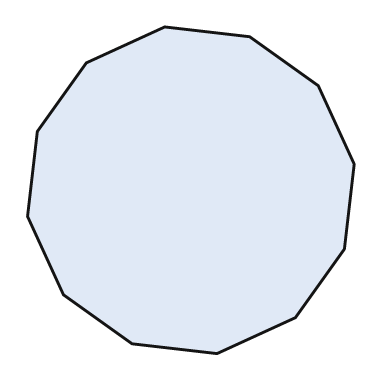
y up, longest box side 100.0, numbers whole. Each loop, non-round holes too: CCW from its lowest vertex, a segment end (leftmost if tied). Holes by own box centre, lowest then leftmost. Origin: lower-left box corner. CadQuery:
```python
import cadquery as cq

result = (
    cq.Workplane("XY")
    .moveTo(58.0, 0.0)
    .lineTo(82.0, 11.0)
    .lineTo(97.0, 32.0)
    .lineTo(100.0, 58.0)
    .lineTo(89.0, 82.0)
    .lineTo(68.0, 97.0)
    .lineTo(42.0, 100.0)
    .lineTo(18.0, 89.0)
    .lineTo(3.0, 68.0)
    .lineTo(0.0, 42.0)
    .lineTo(11.0, 18.0)
    .lineTo(32.0, 3.0)
    .close()
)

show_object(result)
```